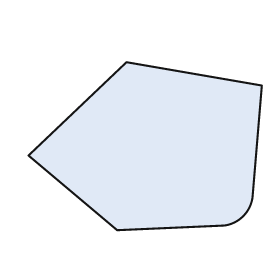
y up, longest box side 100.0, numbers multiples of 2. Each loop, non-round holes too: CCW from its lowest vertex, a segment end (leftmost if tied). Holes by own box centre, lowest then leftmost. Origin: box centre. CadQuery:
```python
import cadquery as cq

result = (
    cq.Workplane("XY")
    .moveTo(-12.0, -36.0)
    .lineTo(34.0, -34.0)
    .threePointArc((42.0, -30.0), (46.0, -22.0))
    .lineTo(50.0, 26.0)
    .lineTo(-8.0, 36.0)
    .lineTo(-50.0, -4.0)
    .close()
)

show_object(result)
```